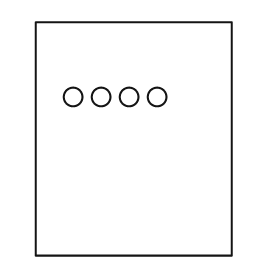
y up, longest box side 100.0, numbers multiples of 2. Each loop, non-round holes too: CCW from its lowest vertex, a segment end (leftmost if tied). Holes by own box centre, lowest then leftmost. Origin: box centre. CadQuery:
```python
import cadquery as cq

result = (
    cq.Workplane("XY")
    .moveTo(-42.0, -50.0)
    .lineTo(42.0, -50.0)
    .lineTo(42.0, 50.0)
    .lineTo(-42.0, 50.0)
    .close()
    .moveTo(-26.0, 18.0)
    .circle(4.0)
    .moveTo(-14.0, 18.0)
    .circle(4.0)
    .moveTo(-2.0, 18.0)
    .circle(4.0)
    .moveTo(10.0, 18.0)
    .circle(4.0)
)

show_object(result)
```